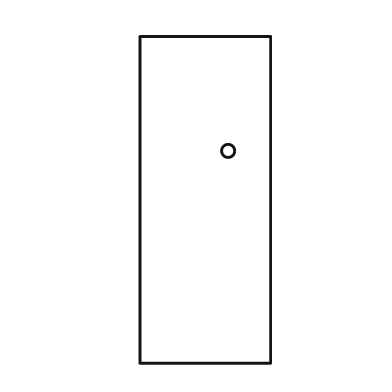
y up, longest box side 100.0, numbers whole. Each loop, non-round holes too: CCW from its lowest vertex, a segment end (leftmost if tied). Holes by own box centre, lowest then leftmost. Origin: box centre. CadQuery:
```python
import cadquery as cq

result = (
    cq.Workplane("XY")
    .moveTo(-20.0, -50.0)
    .lineTo(20.0, -50.0)
    .lineTo(20.0, 50.0)
    .lineTo(-20.0, 50.0)
    .close()
    .moveTo(7.0, 15.0)
    .circle(2.0)
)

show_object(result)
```